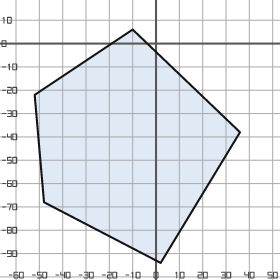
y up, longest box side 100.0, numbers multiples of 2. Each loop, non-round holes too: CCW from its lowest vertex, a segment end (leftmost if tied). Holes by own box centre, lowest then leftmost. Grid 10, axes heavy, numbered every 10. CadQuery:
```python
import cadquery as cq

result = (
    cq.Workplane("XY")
    .moveTo(2.0, -94.0)
    .lineTo(36.0, -38.0)
    .lineTo(-10.0, 6.0)
    .lineTo(-52.0, -22.0)
    .lineTo(-48.0, -68.0)
    .close()
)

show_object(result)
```